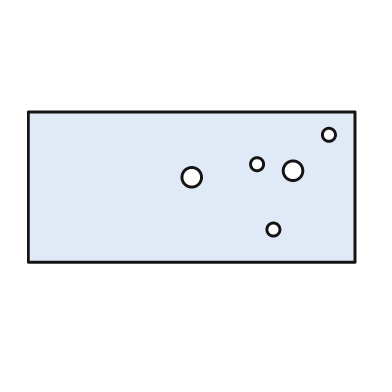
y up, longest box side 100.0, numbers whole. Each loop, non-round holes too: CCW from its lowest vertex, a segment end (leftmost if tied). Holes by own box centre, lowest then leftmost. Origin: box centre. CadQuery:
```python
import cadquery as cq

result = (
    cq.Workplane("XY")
    .moveTo(-50.0, -23.0)
    .lineTo(50.0, -23.0)
    .lineTo(50.0, 23.0)
    .lineTo(-50.0, 23.0)
    .close()
    .moveTo(25.0, -13.0)
    .circle(2.0)
    .moveTo(0.0, 3.0)
    .circle(3.0)
    .moveTo(31.0, 5.0)
    .circle(3.0)
    .moveTo(20.0, 7.0)
    .circle(2.0)
    .moveTo(42.0, 16.0)
    .circle(2.0)
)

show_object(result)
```